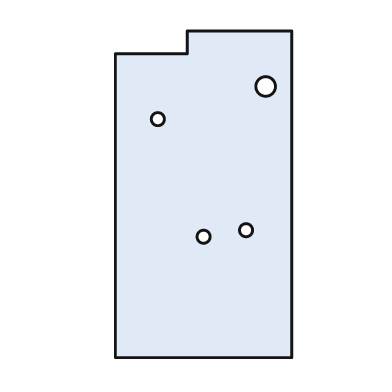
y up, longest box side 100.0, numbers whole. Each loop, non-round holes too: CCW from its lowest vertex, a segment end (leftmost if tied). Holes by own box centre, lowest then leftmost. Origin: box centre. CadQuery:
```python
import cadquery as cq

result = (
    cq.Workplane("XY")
    .moveTo(-27.0, -50.0)
    .lineTo(27.0, -50.0)
    .lineTo(27.0, 50.0)
    .lineTo(-5.0, 50.0)
    .lineTo(-5.0, 43.0)
    .lineTo(-27.0, 43.0)
    .close()
    .moveTo(0.0, -13.0)
    .circle(2.0)
    .moveTo(13.0, -11.0)
    .circle(2.0)
    .moveTo(-14.0, 23.0)
    .circle(2.0)
    .moveTo(19.0, 33.0)
    .circle(3.0)
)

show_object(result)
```